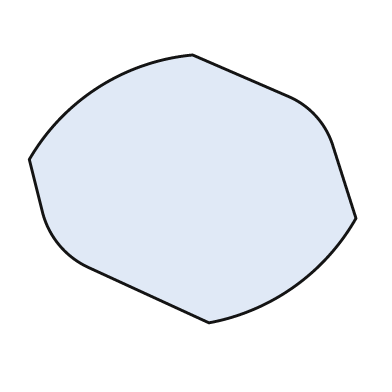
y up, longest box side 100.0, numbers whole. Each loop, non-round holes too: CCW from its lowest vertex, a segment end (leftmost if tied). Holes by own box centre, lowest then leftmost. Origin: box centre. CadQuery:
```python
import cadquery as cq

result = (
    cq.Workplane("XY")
    .moveTo(5.0, -41.0)
    .threePointArc((31.0, -30.0), (50.0, -9.0))
    .lineTo(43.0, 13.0)
    .threePointArc((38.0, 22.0), (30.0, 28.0))
    .lineTo(0.0, 41.0)
    .threePointArc((-29.0, 31.0), (-50.0, 9.0))
    .lineTo(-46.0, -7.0)
    .threePointArc((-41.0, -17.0), (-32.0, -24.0))
    .close()
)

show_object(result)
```